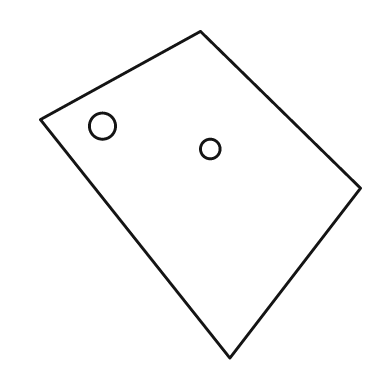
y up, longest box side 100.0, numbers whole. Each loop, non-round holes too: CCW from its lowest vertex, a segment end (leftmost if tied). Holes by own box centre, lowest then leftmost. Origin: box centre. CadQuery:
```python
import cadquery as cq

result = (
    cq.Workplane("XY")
    .moveTo(9.0, -50.0)
    .lineTo(49.0, 2.0)
    .lineTo(0.0, 50.0)
    .lineTo(-49.0, 23.0)
    .close()
    .moveTo(3.0, 14.0)
    .circle(3.0)
    .moveTo(-30.0, 21.0)
    .circle(4.0)
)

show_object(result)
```